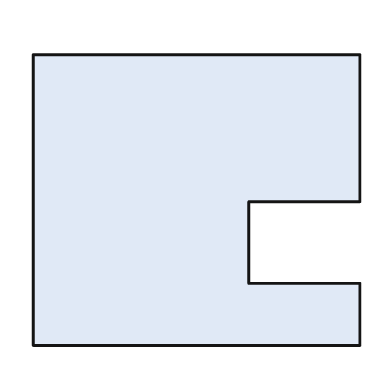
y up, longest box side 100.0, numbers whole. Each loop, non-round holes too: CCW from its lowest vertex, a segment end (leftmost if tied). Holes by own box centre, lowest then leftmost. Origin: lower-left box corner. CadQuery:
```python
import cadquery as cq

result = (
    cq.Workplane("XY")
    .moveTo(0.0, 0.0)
    .lineTo(100.0, 0.0)
    .lineTo(100.0, 19.0)
    .lineTo(66.0, 19.0)
    .lineTo(66.0, 44.0)
    .lineTo(100.0, 44.0)
    .lineTo(100.0, 89.0)
    .lineTo(0.0, 89.0)
    .close()
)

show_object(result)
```